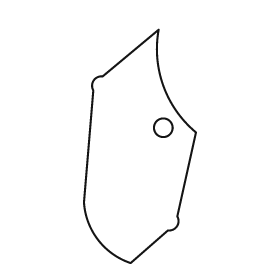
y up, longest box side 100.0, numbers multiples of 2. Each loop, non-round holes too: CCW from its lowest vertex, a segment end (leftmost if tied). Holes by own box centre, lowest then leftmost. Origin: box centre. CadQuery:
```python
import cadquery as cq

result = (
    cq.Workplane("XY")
    .moveTo(-4.0, -50.0)
    .lineTo(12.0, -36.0)
    .threePointArc((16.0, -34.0), (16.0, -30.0))
    .lineTo(24.0, 6.0)
    .threePointArc((10.0, 26.0), (8.0, 50.0))
    .lineTo(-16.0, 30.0)
    .threePointArc((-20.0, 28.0), (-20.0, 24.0))
    .lineTo(-24.0, -24.0)
    .threePointArc((-18.0, -40.0), (-4.0, -50.0))
    .close()
    .moveTo(10.0, 8.0)
    .circle(4.0)
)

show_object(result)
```